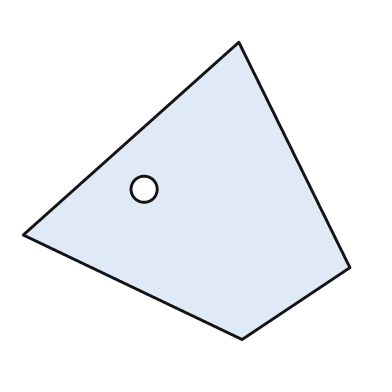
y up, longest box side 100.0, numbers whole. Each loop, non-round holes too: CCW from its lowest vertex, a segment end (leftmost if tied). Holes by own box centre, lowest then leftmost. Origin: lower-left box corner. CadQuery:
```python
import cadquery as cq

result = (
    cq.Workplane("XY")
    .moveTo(67.0, 0.0)
    .lineTo(100.0, 22.0)
    .lineTo(66.0, 91.0)
    .lineTo(0.0, 32.0)
    .close()
    .moveTo(37.0, 46.0)
    .circle(4.0)
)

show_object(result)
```